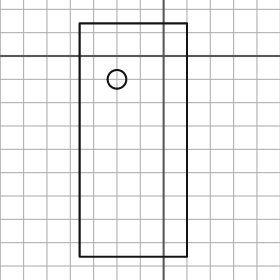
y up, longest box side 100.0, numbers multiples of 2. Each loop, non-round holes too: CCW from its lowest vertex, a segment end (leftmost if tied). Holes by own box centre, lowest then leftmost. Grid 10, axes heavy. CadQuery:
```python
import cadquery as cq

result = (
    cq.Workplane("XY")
    .moveTo(-36.0, -86.0)
    .lineTo(10.0, -86.0)
    .lineTo(10.0, 14.0)
    .lineTo(-36.0, 14.0)
    .close()
    .moveTo(-20.0, -10.0)
    .circle(4.0)
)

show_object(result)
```